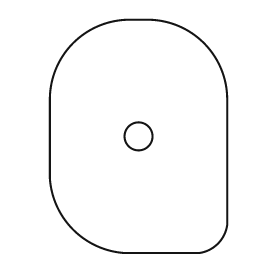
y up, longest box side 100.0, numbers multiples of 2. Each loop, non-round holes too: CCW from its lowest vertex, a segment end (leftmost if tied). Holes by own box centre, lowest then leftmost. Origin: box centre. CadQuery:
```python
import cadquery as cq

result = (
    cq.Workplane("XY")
    .moveTo(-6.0, -50.0)
    .lineTo(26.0, -50.0)
    .threePointArc((34.0, -46.0), (38.0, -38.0))
    .lineTo(38.0, 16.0)
    .threePointArc((28.0, 40.0), (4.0, 50.0))
    .lineTo(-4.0, 50.0)
    .threePointArc((-28.0, 40.0), (-38.0, 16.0))
    .lineTo(-38.0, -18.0)
    .threePointArc((-28.0, -40.0), (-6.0, -50.0))
    .close()
    .moveTo(0.0, 0.0)
    .circle(6.0)
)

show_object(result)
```